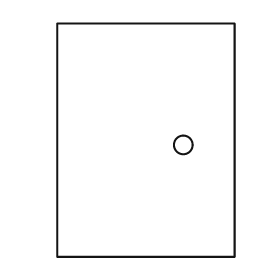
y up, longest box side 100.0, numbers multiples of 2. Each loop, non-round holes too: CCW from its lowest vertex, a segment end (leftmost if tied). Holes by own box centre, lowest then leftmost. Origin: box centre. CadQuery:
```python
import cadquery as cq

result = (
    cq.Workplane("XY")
    .moveTo(-38.0, -50.0)
    .lineTo(38.0, -50.0)
    .lineTo(38.0, 50.0)
    .lineTo(-38.0, 50.0)
    .close()
    .moveTo(16.0, -2.0)
    .circle(4.0)
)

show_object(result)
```